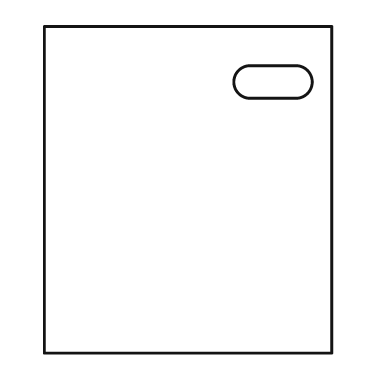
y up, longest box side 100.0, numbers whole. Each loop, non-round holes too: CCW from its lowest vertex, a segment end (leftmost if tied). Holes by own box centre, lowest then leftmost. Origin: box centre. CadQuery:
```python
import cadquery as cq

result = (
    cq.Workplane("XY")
    .moveTo(-44.0, -50.0)
    .lineTo(44.0, -50.0)
    .lineTo(44.0, 50.0)
    .lineTo(-44.0, 50.0)
    .close()
    .moveTo(19.0, 28.0)
    .lineTo(33.0, 28.0)
    .threePointArc((38.0, 33.0), (33.0, 38.0))
    .lineTo(19.0, 38.0)
    .threePointArc((14.0, 33.0), (19.0, 28.0))
    .close()
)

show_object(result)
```